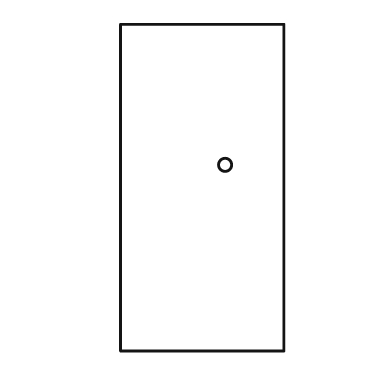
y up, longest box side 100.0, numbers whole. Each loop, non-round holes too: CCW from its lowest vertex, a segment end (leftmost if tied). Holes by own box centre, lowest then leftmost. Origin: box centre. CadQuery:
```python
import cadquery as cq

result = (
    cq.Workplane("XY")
    .moveTo(-25.0, -50.0)
    .lineTo(25.0, -50.0)
    .lineTo(25.0, 50.0)
    .lineTo(-25.0, 50.0)
    .close()
    .moveTo(7.0, 7.0)
    .circle(2.0)
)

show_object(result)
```